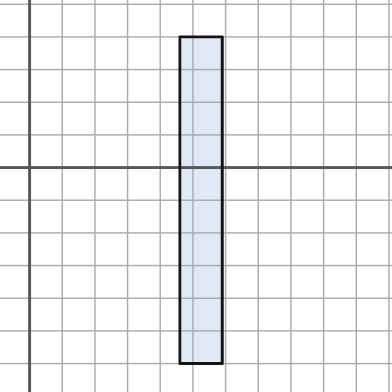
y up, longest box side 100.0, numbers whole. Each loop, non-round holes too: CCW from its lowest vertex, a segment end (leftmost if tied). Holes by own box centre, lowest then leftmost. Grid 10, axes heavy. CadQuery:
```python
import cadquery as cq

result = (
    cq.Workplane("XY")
    .moveTo(46.0, -60.0)
    .lineTo(59.0, -60.0)
    .lineTo(59.0, 40.0)
    .lineTo(46.0, 40.0)
    .close()
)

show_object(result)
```